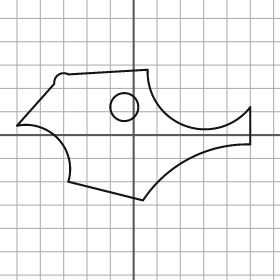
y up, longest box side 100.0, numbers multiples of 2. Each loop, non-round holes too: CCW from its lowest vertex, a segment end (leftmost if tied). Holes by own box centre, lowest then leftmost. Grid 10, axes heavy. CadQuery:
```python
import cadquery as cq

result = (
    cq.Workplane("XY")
    .moveTo(4.0, -28.0)
    .threePointArc((24.0, -10.0), (50.0, -4.0))
    .lineTo(50.0, 12.0)
    .threePointArc((22.0, 4.0), (6.0, 28.0))
    .lineTo(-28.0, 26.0)
    .threePointArc((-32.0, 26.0), (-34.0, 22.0))
    .lineTo(-50.0, 4.0)
    .threePointArc((-32.0, -2.0), (-28.0, -20.0))
    .close()
    .moveTo(-4.0, 12.0)
    .circle(6.0)
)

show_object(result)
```